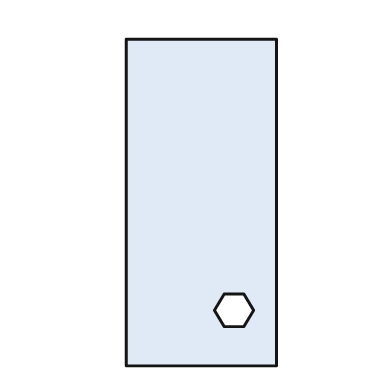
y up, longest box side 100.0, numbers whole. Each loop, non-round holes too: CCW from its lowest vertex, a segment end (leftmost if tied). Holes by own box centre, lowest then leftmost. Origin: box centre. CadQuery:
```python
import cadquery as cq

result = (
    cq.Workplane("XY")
    .moveTo(-23.0, -50.0)
    .lineTo(23.0, -50.0)
    .lineTo(23.0, 50.0)
    .lineTo(-23.0, 50.0)
    .close()
    .moveTo(7.0, -38.0)
    .lineTo(13.0, -38.0)
    .lineTo(16.0, -33.0)
    .lineTo(13.0, -28.0)
    .lineTo(7.0, -28.0)
    .lineTo(4.0, -33.0)
    .close()
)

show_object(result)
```